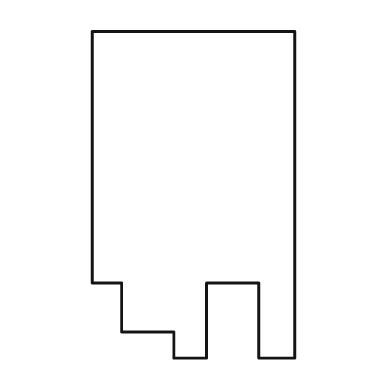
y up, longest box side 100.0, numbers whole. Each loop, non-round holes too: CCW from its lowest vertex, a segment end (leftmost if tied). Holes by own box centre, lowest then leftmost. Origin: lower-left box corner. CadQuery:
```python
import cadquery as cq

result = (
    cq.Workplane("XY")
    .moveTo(25.0, 0.0)
    .lineTo(35.0, 0.0)
    .lineTo(35.0, 23.0)
    .lineTo(51.0, 23.0)
    .lineTo(51.0, 0.0)
    .lineTo(62.0, 0.0)
    .lineTo(62.0, 100.0)
    .lineTo(0.0, 100.0)
    .lineTo(0.0, 23.0)
    .lineTo(9.0, 23.0)
    .lineTo(9.0, 8.0)
    .lineTo(25.0, 8.0)
    .close()
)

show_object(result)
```